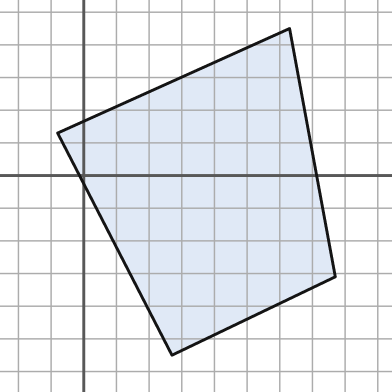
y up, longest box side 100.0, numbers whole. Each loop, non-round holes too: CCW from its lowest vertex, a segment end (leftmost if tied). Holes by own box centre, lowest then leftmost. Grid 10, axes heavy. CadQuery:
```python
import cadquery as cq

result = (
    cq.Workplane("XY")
    .moveTo(27.0, -55.0)
    .lineTo(77.0, -31.0)
    .lineTo(63.0, 45.0)
    .lineTo(-8.0, 13.0)
    .close()
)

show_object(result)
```